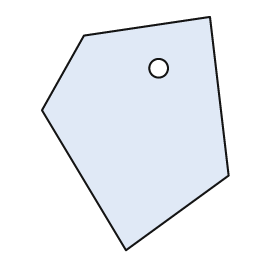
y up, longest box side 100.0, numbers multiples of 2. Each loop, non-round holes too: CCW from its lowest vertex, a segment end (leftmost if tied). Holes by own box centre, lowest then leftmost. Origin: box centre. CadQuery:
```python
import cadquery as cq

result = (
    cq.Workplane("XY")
    .moveTo(-4.0, -50.0)
    .lineTo(40.0, -18.0)
    .lineTo(32.0, 50.0)
    .lineTo(-22.0, 42.0)
    .lineTo(-40.0, 10.0)
    .close()
    .moveTo(10.0, 28.0)
    .circle(4.0)
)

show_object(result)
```